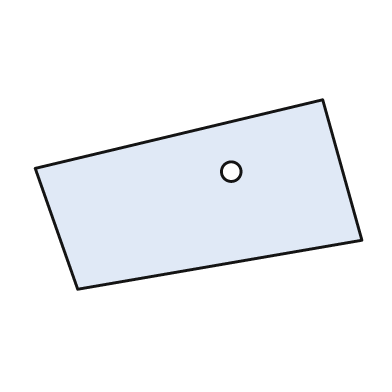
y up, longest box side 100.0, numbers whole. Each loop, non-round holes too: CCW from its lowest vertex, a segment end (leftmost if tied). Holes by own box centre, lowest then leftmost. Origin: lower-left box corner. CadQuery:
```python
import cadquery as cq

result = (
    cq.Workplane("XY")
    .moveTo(13.0, 0.0)
    .lineTo(100.0, 15.0)
    .lineTo(88.0, 58.0)
    .lineTo(0.0, 37.0)
    .close()
    .moveTo(60.0, 36.0)
    .circle(3.0)
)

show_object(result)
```